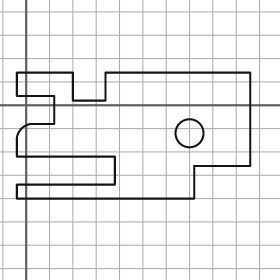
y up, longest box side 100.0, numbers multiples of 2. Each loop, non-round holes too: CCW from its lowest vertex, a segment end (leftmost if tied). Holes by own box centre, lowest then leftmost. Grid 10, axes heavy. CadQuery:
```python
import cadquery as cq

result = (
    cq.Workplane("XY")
    .moveTo(-4.0, -40.0)
    .lineTo(72.0, -40.0)
    .lineTo(72.0, -26.0)
    .lineTo(96.0, -26.0)
    .lineTo(96.0, 14.0)
    .lineTo(34.0, 14.0)
    .lineTo(34.0, 2.0)
    .lineTo(20.0, 2.0)
    .lineTo(20.0, 14.0)
    .lineTo(-4.0, 14.0)
    .lineTo(-4.0, 4.0)
    .lineTo(12.0, 4.0)
    .lineTo(12.0, -8.0)
    .lineTo(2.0, -8.0)
    .threePointArc((-2.0, -10.0), (-4.0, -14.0))
    .lineTo(-4.0, -22.0)
    .lineTo(38.0, -22.0)
    .lineTo(38.0, -34.0)
    .lineTo(-4.0, -34.0)
    .close()
    .moveTo(70.0, -12.0)
    .circle(6.0)
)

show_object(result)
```